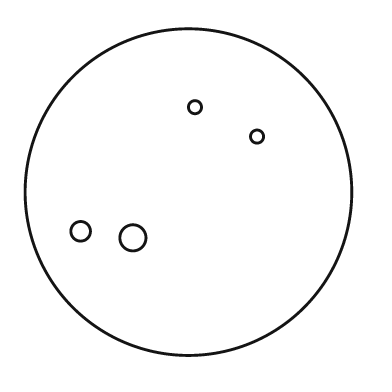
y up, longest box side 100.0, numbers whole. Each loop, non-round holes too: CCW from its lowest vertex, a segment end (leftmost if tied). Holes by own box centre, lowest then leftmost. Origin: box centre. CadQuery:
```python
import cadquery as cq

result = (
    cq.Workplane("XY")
    .moveTo(0.0, 0.0)
    .circle(50.0)
    .moveTo(-17.0, -14.0)
    .circle(4.0)
    .moveTo(-33.0, -12.0)
    .circle(3.0)
    .moveTo(21.0, 17.0)
    .circle(2.0)
    .moveTo(2.0, 26.0)
    .circle(2.0)
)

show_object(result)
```